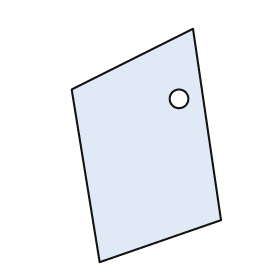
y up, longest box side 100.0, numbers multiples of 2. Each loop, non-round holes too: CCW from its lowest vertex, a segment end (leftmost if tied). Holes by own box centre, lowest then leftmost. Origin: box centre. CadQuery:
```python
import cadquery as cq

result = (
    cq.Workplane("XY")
    .moveTo(-20.0, -50.0)
    .lineTo(32.0, -32.0)
    .lineTo(20.0, 50.0)
    .lineTo(-32.0, 24.0)
    .close()
    .moveTo(14.0, 20.0)
    .circle(4.0)
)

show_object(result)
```